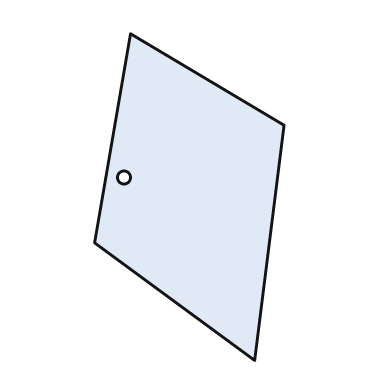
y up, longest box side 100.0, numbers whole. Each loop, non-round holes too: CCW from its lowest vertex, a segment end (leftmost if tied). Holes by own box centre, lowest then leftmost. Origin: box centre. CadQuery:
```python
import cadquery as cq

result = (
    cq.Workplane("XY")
    .moveTo(20.0, -50.0)
    .lineTo(29.0, 22.0)
    .lineTo(-18.0, 50.0)
    .lineTo(-29.0, -14.0)
    .close()
    .moveTo(-20.0, 6.0)
    .circle(2.0)
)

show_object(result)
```